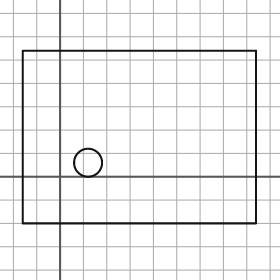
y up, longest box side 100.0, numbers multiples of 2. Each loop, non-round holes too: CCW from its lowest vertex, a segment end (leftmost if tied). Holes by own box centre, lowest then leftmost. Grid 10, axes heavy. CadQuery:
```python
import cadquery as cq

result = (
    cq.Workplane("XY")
    .moveTo(-16.0, -20.0)
    .lineTo(84.0, -20.0)
    .lineTo(84.0, 54.0)
    .lineTo(-16.0, 54.0)
    .close()
    .moveTo(12.0, 6.0)
    .circle(6.0)
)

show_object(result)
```